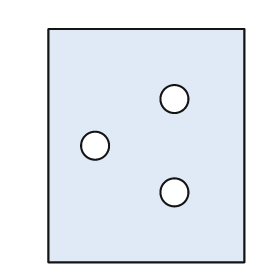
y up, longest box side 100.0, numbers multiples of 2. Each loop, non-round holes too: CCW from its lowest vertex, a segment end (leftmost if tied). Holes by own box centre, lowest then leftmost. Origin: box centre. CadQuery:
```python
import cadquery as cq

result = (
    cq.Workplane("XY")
    .moveTo(-42.0, -50.0)
    .lineTo(42.0, -50.0)
    .lineTo(42.0, 50.0)
    .lineTo(-42.0, 50.0)
    .close()
    .moveTo(12.0, -20.0)
    .circle(6.0)
    .moveTo(-22.0, 0.0)
    .circle(6.0)
    .moveTo(12.0, 20.0)
    .circle(6.0)
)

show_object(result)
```